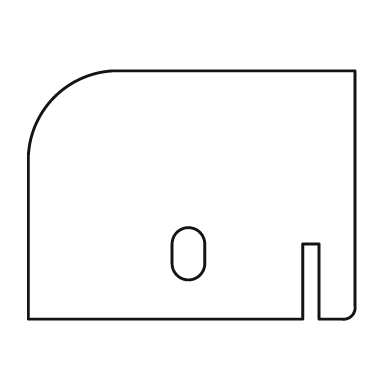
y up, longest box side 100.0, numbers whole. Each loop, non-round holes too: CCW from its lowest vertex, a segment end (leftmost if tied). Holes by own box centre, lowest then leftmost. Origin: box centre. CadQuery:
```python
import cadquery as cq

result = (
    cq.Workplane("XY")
    .moveTo(-50.0, -38.0)
    .lineTo(34.0, -38.0)
    .lineTo(34.0, -15.0)
    .lineTo(39.0, -15.0)
    .lineTo(39.0, -38.0)
    .lineTo(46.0, -38.0)
    .threePointArc((49.0, -37.0), (50.0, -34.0))
    .lineTo(50.0, 38.0)
    .lineTo(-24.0, 38.0)
    .threePointArc((-42.0, 30.0), (-50.0, 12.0))
    .close()
    .moveTo(-6.0, -21.0)
    .threePointArc((-1.0, -26.0), (4.0, -21.0))
    .lineTo(4.0, -15.0)
    .threePointArc((-1.0, -10.0), (-6.0, -15.0))
    .close()
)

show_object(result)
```